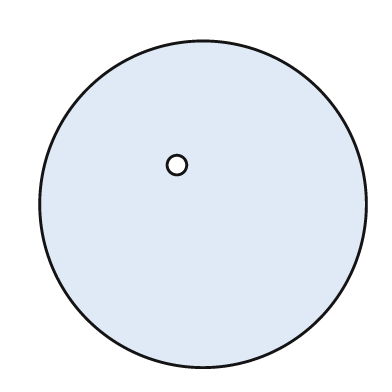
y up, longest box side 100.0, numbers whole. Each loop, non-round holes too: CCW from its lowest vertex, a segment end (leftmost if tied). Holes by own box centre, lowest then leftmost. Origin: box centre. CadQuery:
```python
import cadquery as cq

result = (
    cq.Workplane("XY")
    .moveTo(0.0, 0.0)
    .circle(50.0)
    .moveTo(-8.0, 12.0)
    .circle(3.0)
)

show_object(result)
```